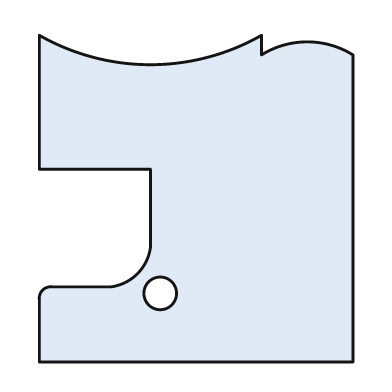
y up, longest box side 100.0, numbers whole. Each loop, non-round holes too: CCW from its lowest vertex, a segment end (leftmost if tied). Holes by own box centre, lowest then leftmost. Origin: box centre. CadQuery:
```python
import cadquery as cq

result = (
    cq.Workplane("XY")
    .moveTo(-48.0, -50.0)
    .lineTo(48.0, -50.0)
    .lineTo(48.0, 44.0)
    .threePointArc((34.0, 48.0), (20.0, 44.0))
    .lineTo(20.0, 50.0)
    .threePointArc((-14.0, 41.0), (-48.0, 50.0))
    .lineTo(-48.0, 9.0)
    .lineTo(-14.0, 9.0)
    .lineTo(-14.0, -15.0)
    .threePointArc((-18.0, -23.0), (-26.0, -27.0))
    .lineTo(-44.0, -27.0)
    .threePointArc((-47.0, -28.0), (-48.0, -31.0))
    .close()
    .moveTo(-11.0, -29.0)
    .circle(5.0)
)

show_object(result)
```